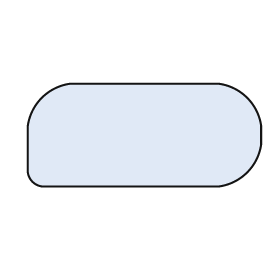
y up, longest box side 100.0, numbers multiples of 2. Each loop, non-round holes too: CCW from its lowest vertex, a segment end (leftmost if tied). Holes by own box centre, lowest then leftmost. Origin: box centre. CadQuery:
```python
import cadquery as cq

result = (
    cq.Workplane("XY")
    .moveTo(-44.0, -22.0)
    .lineTo(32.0, -22.0)
    .threePointArc((44.0, -16.0), (50.0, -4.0))
    .lineTo(50.0, 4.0)
    .threePointArc((44.0, 16.0), (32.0, 22.0))
    .lineTo(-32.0, 22.0)
    .threePointArc((-44.0, 16.0), (-50.0, 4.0))
    .lineTo(-50.0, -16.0)
    .threePointArc((-48.0, -20.0), (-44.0, -22.0))
    .close()
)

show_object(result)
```